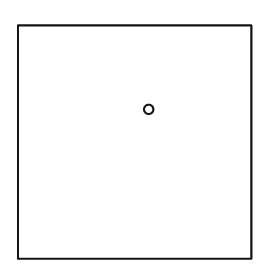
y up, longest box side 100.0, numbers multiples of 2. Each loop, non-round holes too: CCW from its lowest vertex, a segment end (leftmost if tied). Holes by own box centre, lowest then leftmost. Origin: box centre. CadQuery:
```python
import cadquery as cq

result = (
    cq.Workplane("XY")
    .moveTo(-50.0, -50.0)
    .lineTo(50.0, -50.0)
    .lineTo(50.0, 50.0)
    .lineTo(-50.0, 50.0)
    .close()
    .moveTo(6.0, 14.0)
    .circle(2.0)
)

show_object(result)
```